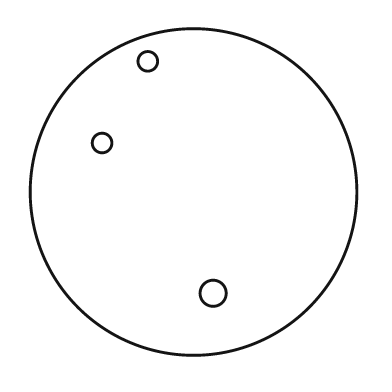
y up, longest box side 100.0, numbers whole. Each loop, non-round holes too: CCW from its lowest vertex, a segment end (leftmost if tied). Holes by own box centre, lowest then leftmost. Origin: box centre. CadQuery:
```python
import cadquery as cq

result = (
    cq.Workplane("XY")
    .moveTo(0.0, 0.0)
    .circle(50.0)
    .moveTo(6.0, -31.0)
    .circle(4.0)
    .moveTo(-28.0, 15.0)
    .circle(3.0)
    .moveTo(-14.0, 40.0)
    .circle(3.0)
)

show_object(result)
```